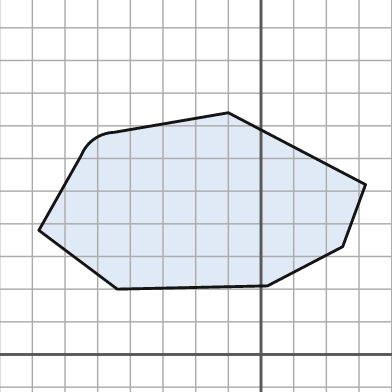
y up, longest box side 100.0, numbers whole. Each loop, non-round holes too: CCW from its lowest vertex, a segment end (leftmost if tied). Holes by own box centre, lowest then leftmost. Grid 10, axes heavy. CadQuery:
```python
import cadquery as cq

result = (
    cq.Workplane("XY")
    .moveTo(-44.0, 20.0)
    .lineTo(2.0, 21.0)
    .lineTo(25.0, 33.0)
    .lineTo(32.0, 52.0)
    .lineTo(-10.0, 74.0)
    .lineTo(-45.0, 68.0)
    .threePointArc((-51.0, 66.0), (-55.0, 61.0))
    .lineTo(-68.0, 38.0)
    .close()
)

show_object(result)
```